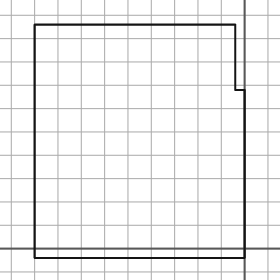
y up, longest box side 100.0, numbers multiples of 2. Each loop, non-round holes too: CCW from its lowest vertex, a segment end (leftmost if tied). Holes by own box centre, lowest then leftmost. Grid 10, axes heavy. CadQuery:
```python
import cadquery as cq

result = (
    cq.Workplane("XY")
    .moveTo(-90.0, -4.0)
    .lineTo(0.0, -4.0)
    .lineTo(0.0, 68.0)
    .lineTo(-4.0, 68.0)
    .lineTo(-4.0, 96.0)
    .lineTo(-90.0, 96.0)
    .close()
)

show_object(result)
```